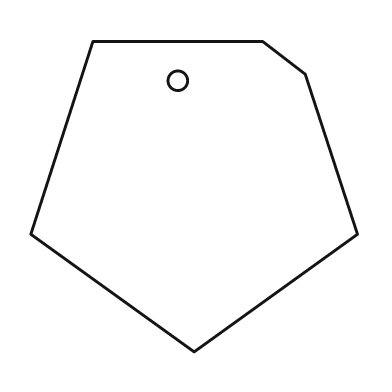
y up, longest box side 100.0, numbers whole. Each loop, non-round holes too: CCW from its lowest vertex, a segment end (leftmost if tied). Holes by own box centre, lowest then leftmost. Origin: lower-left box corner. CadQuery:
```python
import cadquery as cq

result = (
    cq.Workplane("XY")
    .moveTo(50.0, 0.0)
    .lineTo(100.0, 36.0)
    .lineTo(84.0, 85.0)
    .lineTo(71.0, 95.0)
    .lineTo(19.0, 95.0)
    .lineTo(0.0, 36.0)
    .close()
    .moveTo(45.0, 83.0)
    .circle(3.0)
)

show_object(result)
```